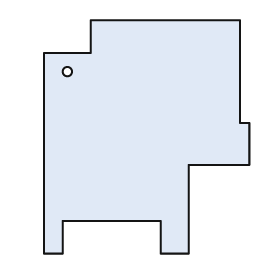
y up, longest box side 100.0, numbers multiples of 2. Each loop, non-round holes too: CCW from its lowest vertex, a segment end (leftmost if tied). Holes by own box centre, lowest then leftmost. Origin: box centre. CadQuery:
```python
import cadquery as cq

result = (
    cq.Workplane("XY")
    .moveTo(-44.0, -50.0)
    .lineTo(-36.0, -50.0)
    .lineTo(-36.0, -36.0)
    .lineTo(6.0, -36.0)
    .lineTo(6.0, -50.0)
    .lineTo(18.0, -50.0)
    .lineTo(18.0, -12.0)
    .lineTo(44.0, -12.0)
    .lineTo(44.0, 6.0)
    .lineTo(40.0, 6.0)
    .lineTo(40.0, 50.0)
    .lineTo(-24.0, 50.0)
    .lineTo(-24.0, 36.0)
    .lineTo(-44.0, 36.0)
    .close()
    .moveTo(-34.0, 28.0)
    .circle(2.0)
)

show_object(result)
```